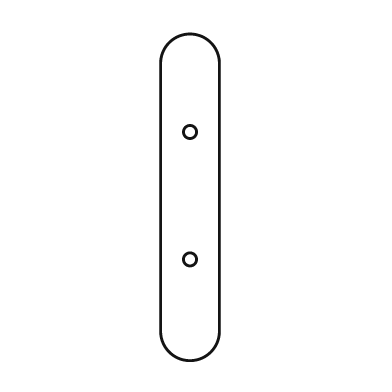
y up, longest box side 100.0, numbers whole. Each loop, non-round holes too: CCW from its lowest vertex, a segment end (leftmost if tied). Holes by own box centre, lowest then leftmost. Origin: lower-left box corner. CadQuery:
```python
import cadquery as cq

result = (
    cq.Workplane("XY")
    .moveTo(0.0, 9.0)
    .threePointArc((9.0, 0.0), (18.0, 9.0))
    .lineTo(18.0, 91.0)
    .threePointArc((9.0, 100.0), (0.0, 91.0))
    .close()
    .moveTo(9.0, 31.0)
    .circle(2.0)
    .moveTo(9.0, 70.0)
    .circle(2.0)
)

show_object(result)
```